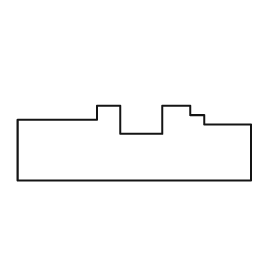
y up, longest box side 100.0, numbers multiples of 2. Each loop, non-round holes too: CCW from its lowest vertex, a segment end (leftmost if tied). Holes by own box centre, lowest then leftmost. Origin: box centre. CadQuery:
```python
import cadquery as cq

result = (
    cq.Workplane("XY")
    .moveTo(-50.0, -16.0)
    .lineTo(50.0, -16.0)
    .lineTo(50.0, 8.0)
    .lineTo(30.0, 8.0)
    .lineTo(30.0, 12.0)
    .lineTo(24.0, 12.0)
    .lineTo(24.0, 16.0)
    .lineTo(12.0, 16.0)
    .lineTo(12.0, 4.0)
    .lineTo(-6.0, 4.0)
    .lineTo(-6.0, 16.0)
    .lineTo(-16.0, 16.0)
    .lineTo(-16.0, 10.0)
    .lineTo(-50.0, 10.0)
    .close()
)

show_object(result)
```